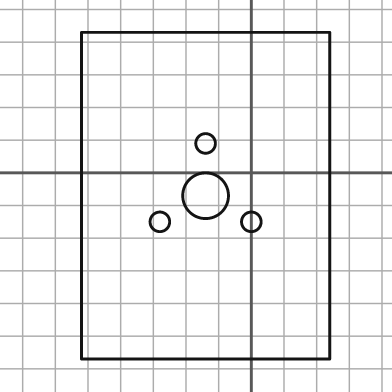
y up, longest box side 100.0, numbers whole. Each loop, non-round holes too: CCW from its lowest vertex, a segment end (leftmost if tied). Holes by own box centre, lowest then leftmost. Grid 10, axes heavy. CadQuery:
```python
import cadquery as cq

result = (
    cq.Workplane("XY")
    .moveTo(-52.0, -57.0)
    .lineTo(24.0, -57.0)
    .lineTo(24.0, 43.0)
    .lineTo(-52.0, 43.0)
    .close()
    .moveTo(-28.0, -15.0)
    .circle(3.0)
    .moveTo(0.0, -15.0)
    .circle(3.0)
    .moveTo(-14.0, -7.0)
    .circle(7.0)
    .moveTo(-14.0, 9.0)
    .circle(3.0)
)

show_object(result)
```